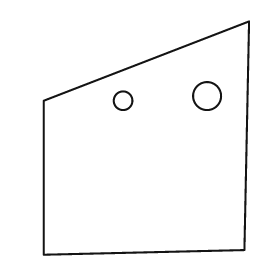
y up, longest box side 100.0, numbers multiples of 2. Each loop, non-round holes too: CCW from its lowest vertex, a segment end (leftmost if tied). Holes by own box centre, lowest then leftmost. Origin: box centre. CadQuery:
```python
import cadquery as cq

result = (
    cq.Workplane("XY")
    .moveTo(-44.0, -50.0)
    .lineTo(42.0, -48.0)
    .lineTo(44.0, 50.0)
    .lineTo(-44.0, 16.0)
    .close()
    .moveTo(-10.0, 16.0)
    .circle(4.0)
    .moveTo(26.0, 18.0)
    .circle(6.0)
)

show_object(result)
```